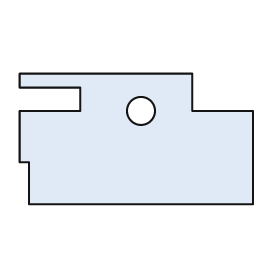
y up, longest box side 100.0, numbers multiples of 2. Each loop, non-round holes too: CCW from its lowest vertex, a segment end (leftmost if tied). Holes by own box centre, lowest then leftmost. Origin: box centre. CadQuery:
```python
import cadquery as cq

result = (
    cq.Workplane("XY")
    .moveTo(-46.0, -28.0)
    .lineTo(50.0, -28.0)
    .lineTo(50.0, 12.0)
    .lineTo(24.0, 12.0)
    .lineTo(24.0, 28.0)
    .lineTo(-50.0, 28.0)
    .lineTo(-50.0, 22.0)
    .lineTo(-24.0, 22.0)
    .lineTo(-24.0, 12.0)
    .lineTo(-50.0, 12.0)
    .lineTo(-50.0, -10.0)
    .lineTo(-46.0, -10.0)
    .close()
    .moveTo(2.0, 12.0)
    .circle(6.0)
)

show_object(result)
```